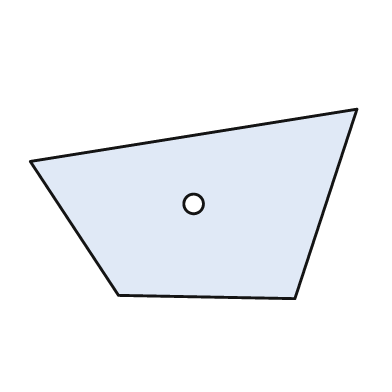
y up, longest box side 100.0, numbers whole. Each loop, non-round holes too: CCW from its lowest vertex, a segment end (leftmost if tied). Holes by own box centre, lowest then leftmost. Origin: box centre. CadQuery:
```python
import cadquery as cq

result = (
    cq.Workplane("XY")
    .moveTo(31.0, -29.0)
    .lineTo(50.0, 29.0)
    .lineTo(-50.0, 13.0)
    .lineTo(-23.0, -28.0)
    .close()
    .moveTo(0.0, 0.0)
    .circle(3.0)
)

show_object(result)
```